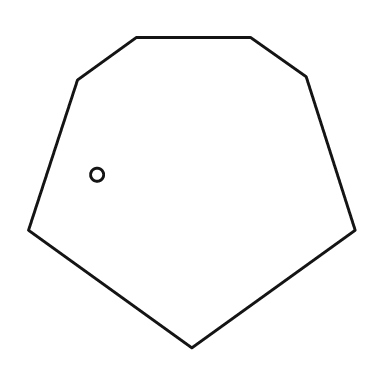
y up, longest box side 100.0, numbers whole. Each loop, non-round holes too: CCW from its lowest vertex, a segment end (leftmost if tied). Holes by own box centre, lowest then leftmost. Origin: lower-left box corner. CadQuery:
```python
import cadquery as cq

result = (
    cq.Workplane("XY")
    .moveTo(50.0, 0.0)
    .lineTo(100.0, 36.0)
    .lineTo(85.0, 83.0)
    .lineTo(68.0, 95.0)
    .lineTo(33.0, 95.0)
    .lineTo(15.0, 82.0)
    .lineTo(0.0, 36.0)
    .close()
    .moveTo(21.0, 53.0)
    .circle(2.0)
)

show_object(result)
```